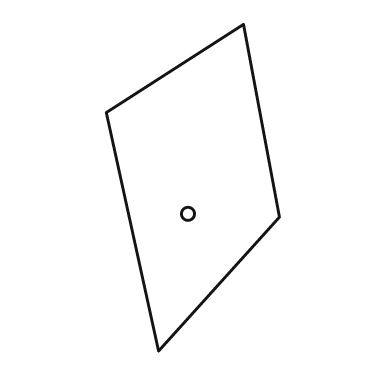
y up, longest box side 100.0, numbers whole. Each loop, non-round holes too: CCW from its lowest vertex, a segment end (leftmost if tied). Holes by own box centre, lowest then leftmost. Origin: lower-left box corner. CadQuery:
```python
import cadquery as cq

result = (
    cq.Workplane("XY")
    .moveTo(16.0, 0.0)
    .lineTo(53.0, 41.0)
    .lineTo(42.0, 100.0)
    .lineTo(0.0, 73.0)
    .close()
    .moveTo(25.0, 42.0)
    .circle(2.0)
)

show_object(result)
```